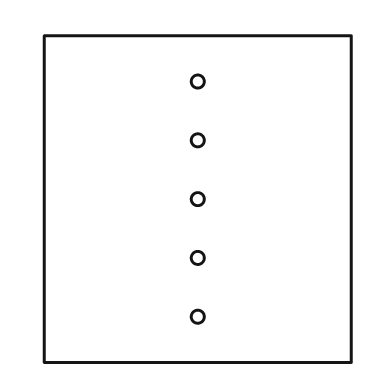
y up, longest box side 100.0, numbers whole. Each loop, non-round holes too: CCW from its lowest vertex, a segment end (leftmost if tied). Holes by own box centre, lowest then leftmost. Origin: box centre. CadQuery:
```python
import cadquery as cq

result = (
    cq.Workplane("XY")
    .moveTo(-47.0, -50.0)
    .lineTo(47.0, -50.0)
    .lineTo(47.0, 50.0)
    .lineTo(-47.0, 50.0)
    .close()
    .moveTo(0.0, -36.0)
    .circle(2.0)
    .moveTo(0.0, -18.0)
    .circle(2.0)
    .moveTo(0.0, 0.0)
    .circle(2.0)
    .moveTo(0.0, 18.0)
    .circle(2.0)
    .moveTo(0.0, 36.0)
    .circle(2.0)
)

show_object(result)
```